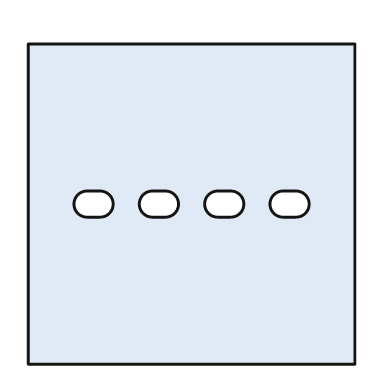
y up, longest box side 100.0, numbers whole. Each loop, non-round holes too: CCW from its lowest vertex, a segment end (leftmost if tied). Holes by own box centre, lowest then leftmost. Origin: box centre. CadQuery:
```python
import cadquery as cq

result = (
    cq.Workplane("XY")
    .moveTo(-50.0, -49.0)
    .lineTo(50.0, -49.0)
    .lineTo(50.0, 49.0)
    .lineTo(-50.0, 49.0)
    .close()
    .moveTo(-32.0, -4.0)
    .lineTo(-28.0, -4.0)
    .threePointArc((-24.0, 0.0), (-28.0, 4.0))
    .lineTo(-32.0, 4.0)
    .threePointArc((-36.0, 0.0), (-32.0, -4.0))
    .close()
    .moveTo(-12.0, -4.0)
    .lineTo(-8.0, -4.0)
    .threePointArc((-4.0, 0.0), (-8.0, 4.0))
    .lineTo(-12.0, 4.0)
    .threePointArc((-16.0, 0.0), (-12.0, -4.0))
    .close()
    .moveTo(8.0, -4.0)
    .lineTo(12.0, -4.0)
    .threePointArc((16.0, 0.0), (12.0, 4.0))
    .lineTo(8.0, 4.0)
    .threePointArc((4.0, 0.0), (8.0, -4.0))
    .close()
    .moveTo(28.0, -4.0)
    .lineTo(32.0, -4.0)
    .threePointArc((36.0, 0.0), (32.0, 4.0))
    .lineTo(28.0, 4.0)
    .threePointArc((24.0, 0.0), (28.0, -4.0))
    .close()
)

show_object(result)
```